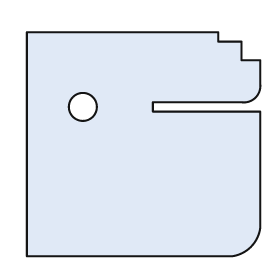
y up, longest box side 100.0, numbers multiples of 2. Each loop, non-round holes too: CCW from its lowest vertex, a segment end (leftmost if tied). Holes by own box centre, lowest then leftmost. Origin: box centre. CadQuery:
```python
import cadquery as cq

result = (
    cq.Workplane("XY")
    .moveTo(-50.0, -48.0)
    .lineTo(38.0, -48.0)
    .threePointArc((46.0, -44.0), (50.0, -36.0))
    .lineTo(50.0, 14.0)
    .lineTo(4.0, 14.0)
    .lineTo(4.0, 18.0)
    .lineTo(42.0, 18.0)
    .threePointArc((48.0, 20.0), (50.0, 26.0))
    .lineTo(50.0, 36.0)
    .lineTo(42.0, 36.0)
    .lineTo(42.0, 44.0)
    .lineTo(32.0, 44.0)
    .lineTo(32.0, 48.0)
    .lineTo(-50.0, 48.0)
    .close()
    .moveTo(-26.0, 16.0)
    .circle(6.0)
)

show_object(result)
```